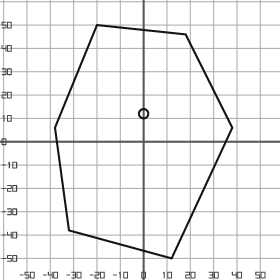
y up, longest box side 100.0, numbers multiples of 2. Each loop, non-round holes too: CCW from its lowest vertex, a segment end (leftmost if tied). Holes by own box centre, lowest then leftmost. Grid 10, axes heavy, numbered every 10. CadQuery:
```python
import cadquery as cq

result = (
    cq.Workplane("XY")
    .moveTo(12.0, -50.0)
    .lineTo(38.0, 6.0)
    .lineTo(18.0, 46.0)
    .lineTo(-20.0, 50.0)
    .lineTo(-38.0, 6.0)
    .lineTo(-32.0, -38.0)
    .close()
    .moveTo(0.0, 12.0)
    .circle(2.0)
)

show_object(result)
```